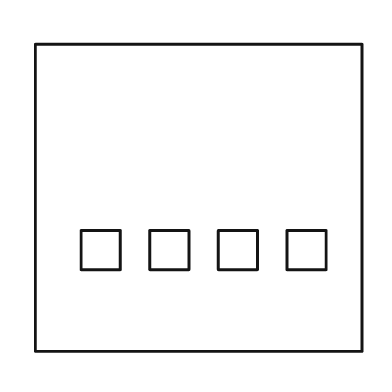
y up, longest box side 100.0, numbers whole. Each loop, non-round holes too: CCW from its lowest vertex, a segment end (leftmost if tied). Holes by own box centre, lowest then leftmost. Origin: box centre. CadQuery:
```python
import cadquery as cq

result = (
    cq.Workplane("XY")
    .moveTo(-50.0, -47.0)
    .lineTo(50.0, -47.0)
    .lineTo(50.0, 47.0)
    .lineTo(-50.0, 47.0)
    .close()
    .moveTo(-36.0, -22.0)
    .lineTo(-24.0, -22.0)
    .lineTo(-24.0, -10.0)
    .lineTo(-36.0, -10.0)
    .close()
    .moveTo(-15.0, -22.0)
    .lineTo(-3.0, -22.0)
    .lineTo(-3.0, -10.0)
    .lineTo(-15.0, -10.0)
    .close()
    .moveTo(6.0, -22.0)
    .lineTo(18.0, -22.0)
    .lineTo(18.0, -10.0)
    .lineTo(6.0, -10.0)
    .close()
    .moveTo(27.0, -22.0)
    .lineTo(39.0, -22.0)
    .lineTo(39.0, -10.0)
    .lineTo(27.0, -10.0)
    .close()
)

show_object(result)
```